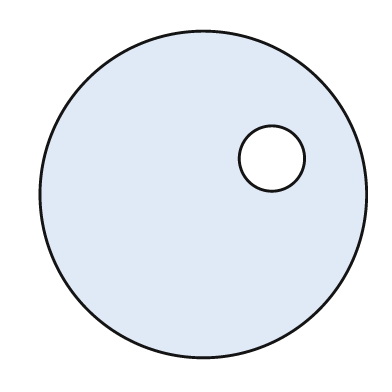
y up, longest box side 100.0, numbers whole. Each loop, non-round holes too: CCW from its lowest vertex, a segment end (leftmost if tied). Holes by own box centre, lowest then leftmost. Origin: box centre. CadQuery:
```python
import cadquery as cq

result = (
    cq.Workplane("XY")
    .moveTo(0.0, 0.0)
    .circle(50.0)
    .moveTo(21.0, 11.0)
    .circle(10.0)
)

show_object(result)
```